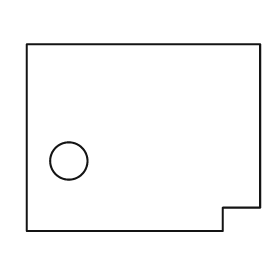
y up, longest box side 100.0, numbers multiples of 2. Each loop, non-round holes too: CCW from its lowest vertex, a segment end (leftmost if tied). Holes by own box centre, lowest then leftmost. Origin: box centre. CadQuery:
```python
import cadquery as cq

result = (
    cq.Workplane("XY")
    .moveTo(-50.0, -40.0)
    .lineTo(34.0, -40.0)
    .lineTo(34.0, -30.0)
    .lineTo(50.0, -30.0)
    .lineTo(50.0, 40.0)
    .lineTo(-50.0, 40.0)
    .close()
    .moveTo(-32.0, -10.0)
    .circle(8.0)
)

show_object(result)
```